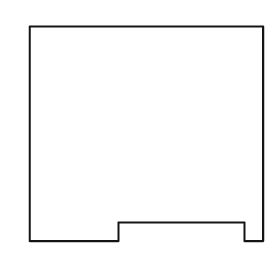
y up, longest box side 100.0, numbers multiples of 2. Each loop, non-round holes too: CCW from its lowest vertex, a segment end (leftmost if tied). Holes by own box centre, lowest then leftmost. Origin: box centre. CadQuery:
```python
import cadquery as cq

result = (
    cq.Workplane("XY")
    .moveTo(-50.0, -46.0)
    .lineTo(-12.0, -46.0)
    .lineTo(-12.0, -38.0)
    .lineTo(42.0, -38.0)
    .lineTo(42.0, -46.0)
    .lineTo(50.0, -46.0)
    .lineTo(50.0, 46.0)
    .lineTo(-50.0, 46.0)
    .close()
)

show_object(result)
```